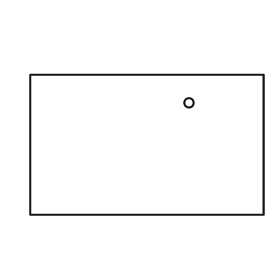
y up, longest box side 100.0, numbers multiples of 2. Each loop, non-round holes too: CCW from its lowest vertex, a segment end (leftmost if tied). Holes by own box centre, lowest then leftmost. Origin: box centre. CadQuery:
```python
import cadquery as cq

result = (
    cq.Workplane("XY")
    .moveTo(-50.0, -30.0)
    .lineTo(50.0, -30.0)
    .lineTo(50.0, 30.0)
    .lineTo(-50.0, 30.0)
    .close()
    .moveTo(18.0, 18.0)
    .circle(2.0)
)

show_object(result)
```